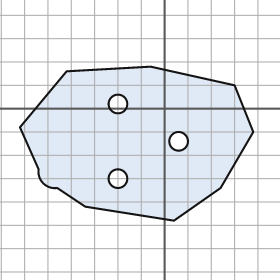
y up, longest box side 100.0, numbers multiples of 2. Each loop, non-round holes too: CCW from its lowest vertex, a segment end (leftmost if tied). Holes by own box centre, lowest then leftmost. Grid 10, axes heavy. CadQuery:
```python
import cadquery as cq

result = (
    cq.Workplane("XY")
    .moveTo(4.0, -48.0)
    .lineTo(24.0, -34.0)
    .lineTo(38.0, -10.0)
    .lineTo(30.0, 10.0)
    .lineTo(-6.0, 18.0)
    .lineTo(-42.0, 16.0)
    .lineTo(-62.0, -8.0)
    .lineTo(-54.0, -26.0)
    .threePointArc((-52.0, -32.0), (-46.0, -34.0))
    .lineTo(-34.0, -42.0)
    .close()
    .moveTo(-20.0, -30.0)
    .circle(4.0)
    .moveTo(6.0, -14.0)
    .circle(4.0)
    .moveTo(-20.0, 2.0)
    .circle(4.0)
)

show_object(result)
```